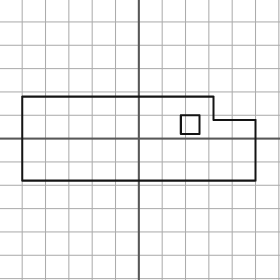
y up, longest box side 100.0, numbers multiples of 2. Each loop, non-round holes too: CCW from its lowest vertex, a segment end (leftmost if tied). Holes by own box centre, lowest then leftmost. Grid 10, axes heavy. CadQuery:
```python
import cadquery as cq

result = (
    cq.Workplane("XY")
    .moveTo(-50.0, -18.0)
    .lineTo(50.0, -18.0)
    .lineTo(50.0, 8.0)
    .lineTo(32.0, 8.0)
    .lineTo(32.0, 18.0)
    .lineTo(-50.0, 18.0)
    .close()
    .moveTo(18.0, 2.0)
    .lineTo(26.0, 2.0)
    .lineTo(26.0, 10.0)
    .lineTo(18.0, 10.0)
    .close()
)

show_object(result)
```